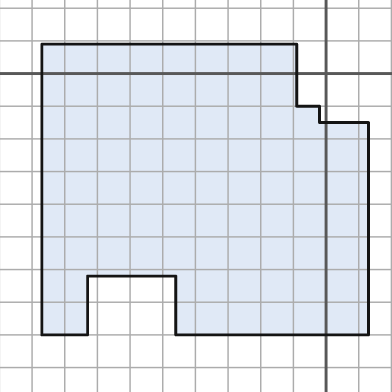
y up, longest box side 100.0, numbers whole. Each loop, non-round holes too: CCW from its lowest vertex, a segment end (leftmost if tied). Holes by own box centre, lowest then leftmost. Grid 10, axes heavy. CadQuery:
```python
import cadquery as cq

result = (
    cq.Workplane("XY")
    .moveTo(-87.0, -80.0)
    .lineTo(-73.0, -80.0)
    .lineTo(-73.0, -62.0)
    .lineTo(-46.0, -62.0)
    .lineTo(-46.0, -80.0)
    .lineTo(13.0, -80.0)
    .lineTo(13.0, -15.0)
    .lineTo(-2.0, -15.0)
    .lineTo(-2.0, -10.0)
    .lineTo(-9.0, -10.0)
    .lineTo(-9.0, 9.0)
    .lineTo(-87.0, 9.0)
    .close()
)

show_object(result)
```